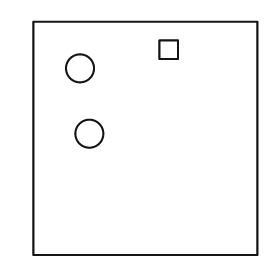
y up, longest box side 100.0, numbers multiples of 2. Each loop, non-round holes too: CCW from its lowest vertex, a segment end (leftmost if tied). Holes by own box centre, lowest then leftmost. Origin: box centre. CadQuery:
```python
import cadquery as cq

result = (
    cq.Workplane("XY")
    .moveTo(-48.0, -50.0)
    .lineTo(48.0, -50.0)
    .lineTo(48.0, 50.0)
    .lineTo(-48.0, 50.0)
    .close()
    .moveTo(-24.0, 2.0)
    .circle(6.0)
    .moveTo(-28.0, 30.0)
    .circle(6.0)
    .moveTo(6.0, 34.0)
    .lineTo(14.0, 34.0)
    .lineTo(14.0, 42.0)
    .lineTo(6.0, 42.0)
    .close()
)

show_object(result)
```